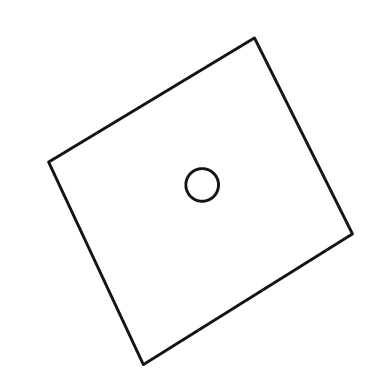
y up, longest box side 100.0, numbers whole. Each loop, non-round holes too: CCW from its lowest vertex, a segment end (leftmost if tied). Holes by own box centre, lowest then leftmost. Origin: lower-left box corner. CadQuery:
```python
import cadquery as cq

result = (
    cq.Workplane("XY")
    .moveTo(29.0, 0.0)
    .lineTo(93.0, 40.0)
    .lineTo(63.0, 100.0)
    .lineTo(0.0, 62.0)
    .close()
    .moveTo(47.0, 55.0)
    .circle(5.0)
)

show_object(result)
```